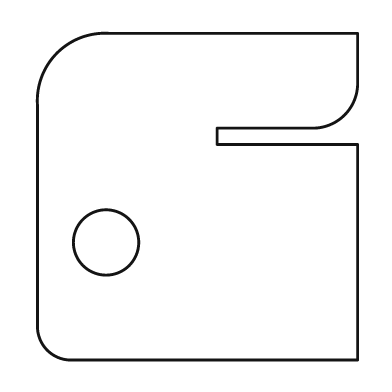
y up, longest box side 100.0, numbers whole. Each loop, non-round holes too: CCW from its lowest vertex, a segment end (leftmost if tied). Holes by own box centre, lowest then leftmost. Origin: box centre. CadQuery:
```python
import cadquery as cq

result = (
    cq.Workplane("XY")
    .moveTo(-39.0, -50.0)
    .lineTo(49.0, -50.0)
    .lineTo(49.0, 16.0)
    .lineTo(6.0, 16.0)
    .lineTo(6.0, 21.0)
    .lineTo(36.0, 21.0)
    .threePointArc((45.0, 25.0), (49.0, 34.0))
    .lineTo(49.0, 50.0)
    .lineTo(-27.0, 50.0)
    .threePointArc((-43.0, 44.0), (-49.0, 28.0))
    .lineTo(-49.0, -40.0)
    .threePointArc((-46.0, -47.0), (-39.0, -50.0))
    .close()
    .moveTo(-28.0, -14.0)
    .circle(10.0)
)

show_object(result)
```